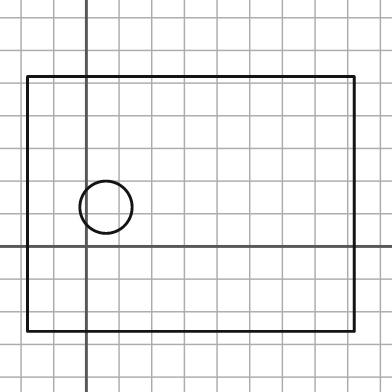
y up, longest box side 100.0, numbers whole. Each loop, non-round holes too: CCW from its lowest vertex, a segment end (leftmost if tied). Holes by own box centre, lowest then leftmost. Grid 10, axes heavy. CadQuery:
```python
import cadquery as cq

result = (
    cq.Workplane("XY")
    .moveTo(-18.0, -26.0)
    .lineTo(82.0, -26.0)
    .lineTo(82.0, 52.0)
    .lineTo(-18.0, 52.0)
    .close()
    .moveTo(6.0, 12.0)
    .circle(8.0)
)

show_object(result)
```